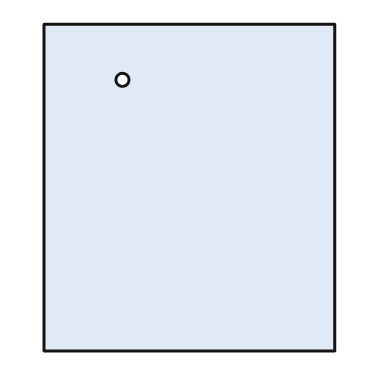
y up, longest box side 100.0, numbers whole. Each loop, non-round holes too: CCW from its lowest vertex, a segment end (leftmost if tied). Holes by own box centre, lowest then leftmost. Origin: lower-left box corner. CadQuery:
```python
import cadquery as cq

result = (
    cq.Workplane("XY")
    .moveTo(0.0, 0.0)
    .lineTo(89.0, 0.0)
    .lineTo(89.0, 100.0)
    .lineTo(0.0, 100.0)
    .close()
    .moveTo(24.0, 83.0)
    .circle(2.0)
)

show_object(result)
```